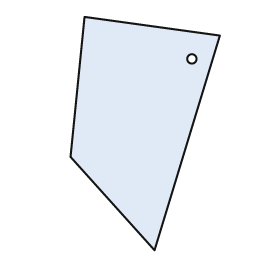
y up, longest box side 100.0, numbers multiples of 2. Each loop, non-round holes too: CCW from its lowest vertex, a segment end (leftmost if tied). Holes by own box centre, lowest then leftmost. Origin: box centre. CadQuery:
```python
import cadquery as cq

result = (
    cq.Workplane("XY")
    .moveTo(4.0, -50.0)
    .lineTo(32.0, 42.0)
    .lineTo(-26.0, 50.0)
    .lineTo(-32.0, -10.0)
    .close()
    .moveTo(20.0, 32.0)
    .circle(2.0)
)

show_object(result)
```